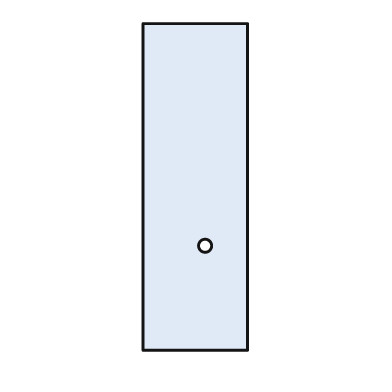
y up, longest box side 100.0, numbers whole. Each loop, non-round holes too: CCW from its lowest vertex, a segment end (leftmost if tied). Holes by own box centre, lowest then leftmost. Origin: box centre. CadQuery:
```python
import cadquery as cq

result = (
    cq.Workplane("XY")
    .moveTo(-16.0, -50.0)
    .lineTo(16.0, -50.0)
    .lineTo(16.0, 50.0)
    .lineTo(-16.0, 50.0)
    .close()
    .moveTo(3.0, -18.0)
    .circle(2.0)
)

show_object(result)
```